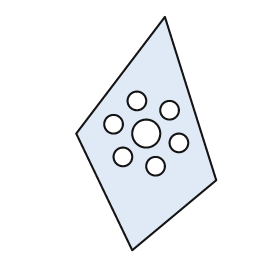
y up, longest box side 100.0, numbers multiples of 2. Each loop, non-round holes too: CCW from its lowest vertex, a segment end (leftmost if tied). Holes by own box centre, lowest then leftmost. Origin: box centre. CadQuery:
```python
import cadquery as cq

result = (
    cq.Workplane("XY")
    .moveTo(-6.0, -50.0)
    .lineTo(30.0, -20.0)
    .lineTo(8.0, 50.0)
    .lineTo(-30.0, 0.0)
    .close()
    .moveTo(4.0, -14.0)
    .circle(4.0)
    .moveTo(-10.0, -10.0)
    .circle(4.0)
    .moveTo(14.0, -4.0)
    .circle(4.0)
    .moveTo(0.0, 0.0)
    .circle(6.0)
    .moveTo(-14.0, 4.0)
    .circle(4.0)
    .moveTo(10.0, 10.0)
    .circle(4.0)
    .moveTo(-4.0, 14.0)
    .circle(4.0)
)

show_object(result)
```